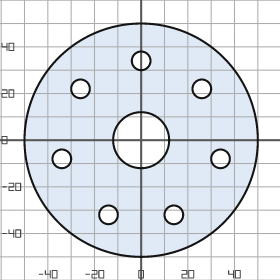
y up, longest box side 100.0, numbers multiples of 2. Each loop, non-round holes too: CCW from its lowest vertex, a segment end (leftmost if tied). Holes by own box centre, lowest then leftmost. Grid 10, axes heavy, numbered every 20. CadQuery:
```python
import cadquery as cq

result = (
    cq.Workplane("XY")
    .moveTo(0.0, 0.0)
    .circle(50.0)
    .moveTo(-14.0, -32.0)
    .circle(4.0)
    .moveTo(14.0, -32.0)
    .circle(4.0)
    .moveTo(-34.0, -8.0)
    .circle(4.0)
    .moveTo(34.0, -8.0)
    .circle(4.0)
    .moveTo(0.0, 0.0)
    .circle(12.0)
    .moveTo(-26.0, 22.0)
    .circle(4.0)
    .moveTo(26.0, 22.0)
    .circle(4.0)
    .moveTo(0.0, 34.0)
    .circle(4.0)
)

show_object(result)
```